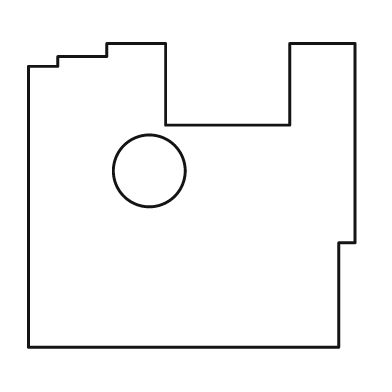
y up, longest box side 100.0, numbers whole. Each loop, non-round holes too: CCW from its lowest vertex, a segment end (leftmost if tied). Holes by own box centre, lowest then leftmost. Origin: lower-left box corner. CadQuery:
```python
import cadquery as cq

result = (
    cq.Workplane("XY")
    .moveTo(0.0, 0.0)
    .lineTo(95.0, 0.0)
    .lineTo(95.0, 32.0)
    .lineTo(100.0, 32.0)
    .lineTo(100.0, 93.0)
    .lineTo(80.0, 93.0)
    .lineTo(80.0, 68.0)
    .lineTo(42.0, 68.0)
    .lineTo(42.0, 93.0)
    .lineTo(24.0, 93.0)
    .lineTo(24.0, 89.0)
    .lineTo(9.0, 89.0)
    .lineTo(9.0, 86.0)
    .lineTo(0.0, 86.0)
    .close()
    .moveTo(37.0, 54.0)
    .circle(11.0)
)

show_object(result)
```